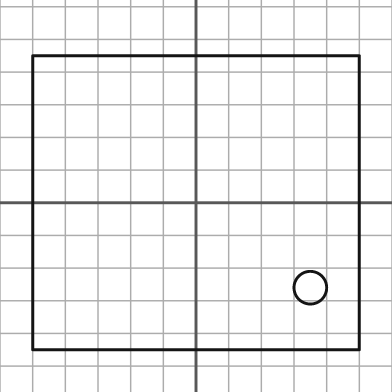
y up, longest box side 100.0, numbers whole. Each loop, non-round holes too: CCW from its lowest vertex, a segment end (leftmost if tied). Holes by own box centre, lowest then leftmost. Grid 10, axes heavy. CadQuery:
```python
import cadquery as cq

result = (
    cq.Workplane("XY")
    .moveTo(-50.0, -45.0)
    .lineTo(50.0, -45.0)
    .lineTo(50.0, 45.0)
    .lineTo(-50.0, 45.0)
    .close()
    .moveTo(35.0, -26.0)
    .circle(5.0)
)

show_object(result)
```